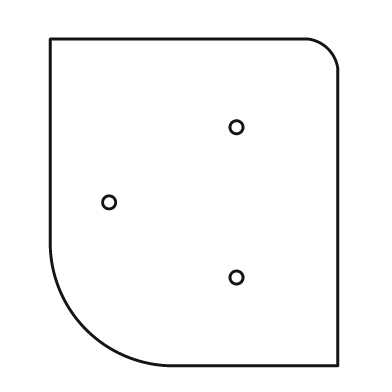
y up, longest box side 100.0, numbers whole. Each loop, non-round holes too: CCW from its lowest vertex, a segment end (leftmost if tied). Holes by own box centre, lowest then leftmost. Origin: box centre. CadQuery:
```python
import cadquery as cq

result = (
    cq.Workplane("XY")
    .moveTo(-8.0, -50.0)
    .lineTo(44.0, -50.0)
    .lineTo(44.0, 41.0)
    .threePointArc((41.0, 47.0), (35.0, 50.0))
    .lineTo(-44.0, 50.0)
    .lineTo(-44.0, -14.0)
    .threePointArc((-33.0, -39.0), (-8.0, -50.0))
    .close()
    .moveTo(13.0, -23.0)
    .circle(2.0)
    .moveTo(-26.0, 0.0)
    .circle(2.0)
    .moveTo(13.0, 23.0)
    .circle(2.0)
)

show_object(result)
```